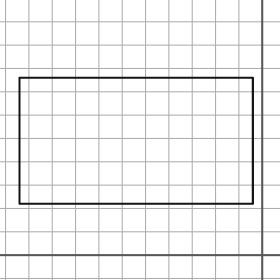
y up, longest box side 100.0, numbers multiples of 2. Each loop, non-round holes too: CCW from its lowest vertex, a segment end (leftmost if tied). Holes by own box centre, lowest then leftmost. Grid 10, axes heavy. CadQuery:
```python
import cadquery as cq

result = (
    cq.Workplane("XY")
    .moveTo(-104.0, 22.0)
    .lineTo(-4.0, 22.0)
    .lineTo(-4.0, 76.0)
    .lineTo(-104.0, 76.0)
    .close()
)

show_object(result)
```